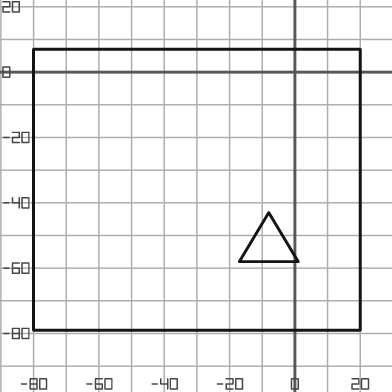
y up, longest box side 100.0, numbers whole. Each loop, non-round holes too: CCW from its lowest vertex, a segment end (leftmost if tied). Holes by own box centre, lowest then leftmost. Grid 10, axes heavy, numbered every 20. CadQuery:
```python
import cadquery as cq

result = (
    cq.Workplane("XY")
    .moveTo(-80.0, -79.0)
    .lineTo(20.0, -79.0)
    .lineTo(20.0, 7.0)
    .lineTo(-80.0, 7.0)
    .close()
    .moveTo(-17.0, -58.0)
    .lineTo(1.0, -58.0)
    .lineTo(-8.0, -43.0)
    .close()
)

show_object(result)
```